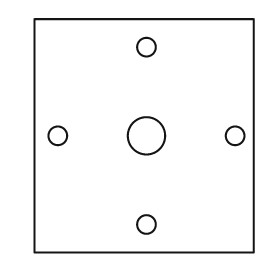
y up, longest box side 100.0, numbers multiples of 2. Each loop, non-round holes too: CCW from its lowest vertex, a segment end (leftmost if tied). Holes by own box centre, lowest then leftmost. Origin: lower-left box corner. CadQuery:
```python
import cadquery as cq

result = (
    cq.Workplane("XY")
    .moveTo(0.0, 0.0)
    .lineTo(94.0, 0.0)
    .lineTo(94.0, 100.0)
    .lineTo(0.0, 100.0)
    .close()
    .moveTo(48.0, 12.0)
    .circle(4.0)
    .moveTo(10.0, 50.0)
    .circle(4.0)
    .moveTo(48.0, 50.0)
    .circle(8.0)
    .moveTo(86.0, 50.0)
    .circle(4.0)
    .moveTo(48.0, 88.0)
    .circle(4.0)
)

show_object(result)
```